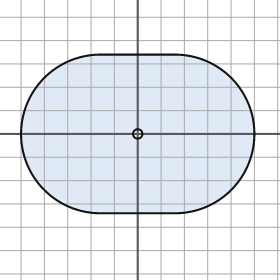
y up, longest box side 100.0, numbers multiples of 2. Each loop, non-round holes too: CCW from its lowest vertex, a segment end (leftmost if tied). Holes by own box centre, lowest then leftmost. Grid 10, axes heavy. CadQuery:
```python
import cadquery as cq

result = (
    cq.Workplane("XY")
    .moveTo(-16.0, -34.0)
    .lineTo(16.0, -34.0)
    .threePointArc((50.0, 0.0), (16.0, 34.0))
    .lineTo(-16.0, 34.0)
    .threePointArc((-50.0, 0.0), (-16.0, -34.0))
    .close()
    .moveTo(0.0, 0.0)
    .circle(2.0)
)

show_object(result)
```